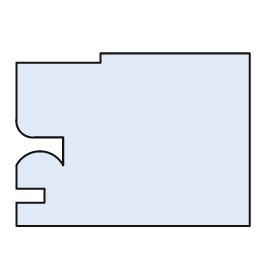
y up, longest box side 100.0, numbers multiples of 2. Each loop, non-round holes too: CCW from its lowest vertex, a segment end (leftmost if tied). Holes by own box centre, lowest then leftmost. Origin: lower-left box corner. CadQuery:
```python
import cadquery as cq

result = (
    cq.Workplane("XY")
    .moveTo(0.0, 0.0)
    .lineTo(100.0, 0.0)
    .lineTo(100.0, 74.0)
    .lineTo(36.0, 74.0)
    .lineTo(36.0, 70.0)
    .lineTo(0.0, 70.0)
    .lineTo(0.0, 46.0)
    .threePointArc((2.0, 40.0), (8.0, 38.0))
    .lineTo(20.0, 38.0)
    .lineTo(20.0, 26.0)
    .threePointArc((10.0, 32.0), (0.0, 26.0))
    .lineTo(0.0, 16.0)
    .lineTo(12.0, 16.0)
    .lineTo(12.0, 10.0)
    .lineTo(0.0, 10.0)
    .close()
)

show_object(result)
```